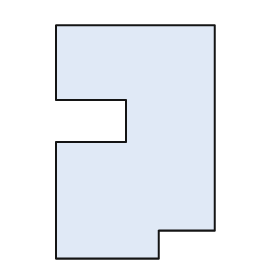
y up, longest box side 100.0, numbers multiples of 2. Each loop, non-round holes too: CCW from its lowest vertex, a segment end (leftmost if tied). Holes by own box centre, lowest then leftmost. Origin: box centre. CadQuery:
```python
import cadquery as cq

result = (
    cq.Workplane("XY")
    .moveTo(-34.0, -50.0)
    .lineTo(10.0, -50.0)
    .lineTo(10.0, -38.0)
    .lineTo(34.0, -38.0)
    .lineTo(34.0, 50.0)
    .lineTo(-34.0, 50.0)
    .lineTo(-34.0, 18.0)
    .lineTo(-4.0, 18.0)
    .lineTo(-4.0, 0.0)
    .lineTo(-34.0, 0.0)
    .close()
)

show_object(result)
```